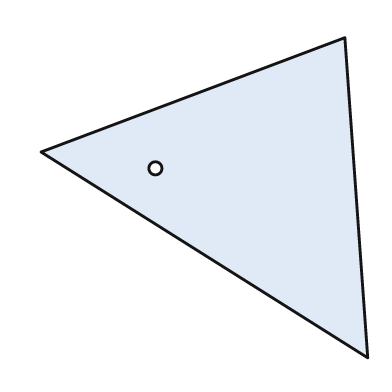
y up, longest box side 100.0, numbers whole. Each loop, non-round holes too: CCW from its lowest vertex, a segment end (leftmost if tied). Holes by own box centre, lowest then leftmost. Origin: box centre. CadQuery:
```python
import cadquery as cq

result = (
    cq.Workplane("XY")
    .moveTo(50.0, -49.0)
    .lineTo(43.0, 49.0)
    .lineTo(-50.0, 14.0)
    .close()
    .moveTo(-15.0, 9.0)
    .circle(2.0)
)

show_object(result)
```